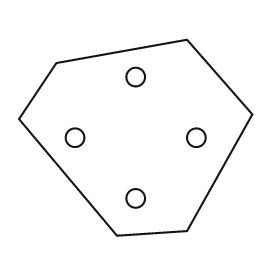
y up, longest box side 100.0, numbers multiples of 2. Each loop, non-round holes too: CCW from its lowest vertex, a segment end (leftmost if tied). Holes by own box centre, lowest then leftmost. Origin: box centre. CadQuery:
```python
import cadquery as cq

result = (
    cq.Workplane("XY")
    .moveTo(-8.0, -42.0)
    .lineTo(22.0, -40.0)
    .lineTo(50.0, 10.0)
    .lineTo(22.0, 42.0)
    .lineTo(-34.0, 32.0)
    .lineTo(-50.0, 8.0)
    .close()
    .moveTo(0.0, -26.0)
    .circle(4.0)
    .moveTo(-26.0, 0.0)
    .circle(4.0)
    .moveTo(26.0, 0.0)
    .circle(4.0)
    .moveTo(0.0, 26.0)
    .circle(4.0)
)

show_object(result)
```